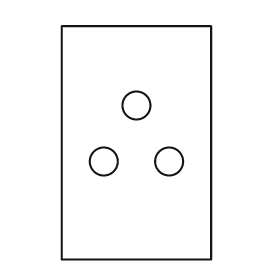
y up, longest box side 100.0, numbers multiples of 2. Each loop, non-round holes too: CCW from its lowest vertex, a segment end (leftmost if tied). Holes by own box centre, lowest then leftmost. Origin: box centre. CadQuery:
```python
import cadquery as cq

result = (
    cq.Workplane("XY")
    .moveTo(-32.0, -50.0)
    .lineTo(32.0, -50.0)
    .lineTo(32.0, 50.0)
    .lineTo(-32.0, 50.0)
    .close()
    .moveTo(-14.0, -8.0)
    .circle(6.0)
    .moveTo(14.0, -8.0)
    .circle(6.0)
    .moveTo(0.0, 16.0)
    .circle(6.0)
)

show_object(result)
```